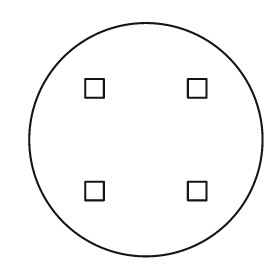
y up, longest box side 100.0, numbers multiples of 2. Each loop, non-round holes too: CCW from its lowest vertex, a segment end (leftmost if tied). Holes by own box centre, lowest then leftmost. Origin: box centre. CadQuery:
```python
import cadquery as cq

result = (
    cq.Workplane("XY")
    .moveTo(0.0, 0.0)
    .circle(50.0)
    .moveTo(-26.0, -26.0)
    .lineTo(-18.0, -26.0)
    .lineTo(-18.0, -18.0)
    .lineTo(-26.0, -18.0)
    .close()
    .moveTo(18.0, -26.0)
    .lineTo(26.0, -26.0)
    .lineTo(26.0, -18.0)
    .lineTo(18.0, -18.0)
    .close()
    .moveTo(-26.0, 18.0)
    .lineTo(-18.0, 18.0)
    .lineTo(-18.0, 26.0)
    .lineTo(-26.0, 26.0)
    .close()
    .moveTo(18.0, 18.0)
    .lineTo(26.0, 18.0)
    .lineTo(26.0, 26.0)
    .lineTo(18.0, 26.0)
    .close()
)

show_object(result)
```